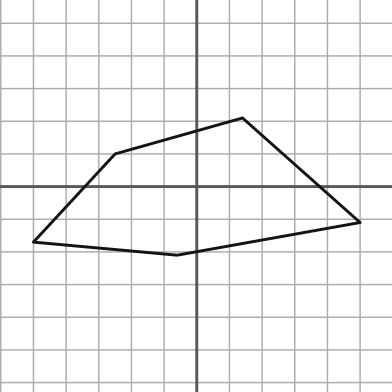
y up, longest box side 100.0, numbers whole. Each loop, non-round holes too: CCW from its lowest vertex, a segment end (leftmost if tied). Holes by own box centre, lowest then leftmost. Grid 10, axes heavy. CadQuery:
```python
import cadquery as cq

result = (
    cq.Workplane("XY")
    .moveTo(-6.0, -21.0)
    .lineTo(50.0, -11.0)
    .lineTo(14.0, 21.0)
    .lineTo(-25.0, 10.0)
    .lineTo(-50.0, -17.0)
    .close()
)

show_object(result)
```